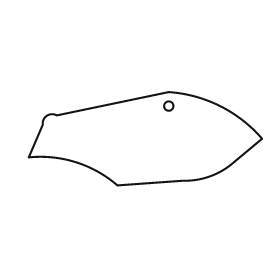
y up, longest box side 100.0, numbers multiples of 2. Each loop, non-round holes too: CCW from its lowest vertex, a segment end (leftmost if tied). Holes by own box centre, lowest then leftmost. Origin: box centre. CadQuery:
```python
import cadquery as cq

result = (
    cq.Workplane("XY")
    .moveTo(-12.0, -20.0)
    .lineTo(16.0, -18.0)
    .threePointArc((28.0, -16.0), (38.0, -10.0))
    .lineTo(50.0, 0.0)
    .threePointArc((32.0, 14.0), (10.0, 20.0))
    .lineTo(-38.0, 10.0)
    .threePointArc((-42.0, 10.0), (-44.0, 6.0))
    .lineTo(-50.0, -8.0)
    .threePointArc((-30.0, -10.0), (-12.0, -20.0))
    .close()
    .moveTo(10.0, 14.0)
    .circle(2.0)
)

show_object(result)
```